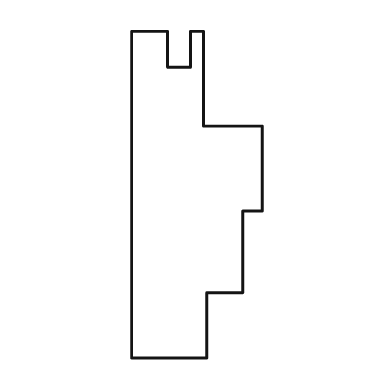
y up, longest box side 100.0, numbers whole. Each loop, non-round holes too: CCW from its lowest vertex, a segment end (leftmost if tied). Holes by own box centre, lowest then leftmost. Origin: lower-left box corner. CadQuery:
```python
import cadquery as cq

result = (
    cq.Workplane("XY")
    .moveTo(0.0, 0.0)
    .lineTo(23.0, 0.0)
    .lineTo(23.0, 20.0)
    .lineTo(34.0, 20.0)
    .lineTo(34.0, 45.0)
    .lineTo(40.0, 45.0)
    .lineTo(40.0, 71.0)
    .lineTo(22.0, 71.0)
    .lineTo(22.0, 100.0)
    .lineTo(18.0, 100.0)
    .lineTo(18.0, 89.0)
    .lineTo(11.0, 89.0)
    .lineTo(11.0, 100.0)
    .lineTo(0.0, 100.0)
    .close()
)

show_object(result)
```